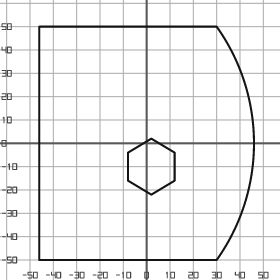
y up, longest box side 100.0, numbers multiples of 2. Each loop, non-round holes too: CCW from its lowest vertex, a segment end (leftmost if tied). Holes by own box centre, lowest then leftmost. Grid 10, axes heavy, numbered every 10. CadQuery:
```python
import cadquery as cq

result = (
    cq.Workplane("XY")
    .moveTo(-46.0, -50.0)
    .lineTo(30.0, -50.0)
    .threePointArc((46.0, 0.0), (30.0, 50.0))
    .lineTo(-46.0, 50.0)
    .close()
    .moveTo(2.0, -22.0)
    .lineTo(12.0, -16.0)
    .lineTo(12.0, -4.0)
    .lineTo(2.0, 2.0)
    .lineTo(-8.0, -4.0)
    .lineTo(-8.0, -16.0)
    .close()
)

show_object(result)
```